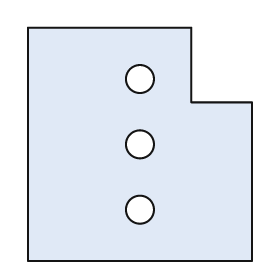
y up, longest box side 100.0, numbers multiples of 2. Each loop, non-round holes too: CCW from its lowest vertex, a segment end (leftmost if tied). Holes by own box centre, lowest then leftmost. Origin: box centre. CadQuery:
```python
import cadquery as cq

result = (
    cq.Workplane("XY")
    .moveTo(-48.0, -50.0)
    .lineTo(48.0, -50.0)
    .lineTo(48.0, 18.0)
    .lineTo(22.0, 18.0)
    .lineTo(22.0, 50.0)
    .lineTo(-48.0, 50.0)
    .close()
    .moveTo(0.0, -28.0)
    .circle(6.0)
    .moveTo(0.0, 0.0)
    .circle(6.0)
    .moveTo(0.0, 28.0)
    .circle(6.0)
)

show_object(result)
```